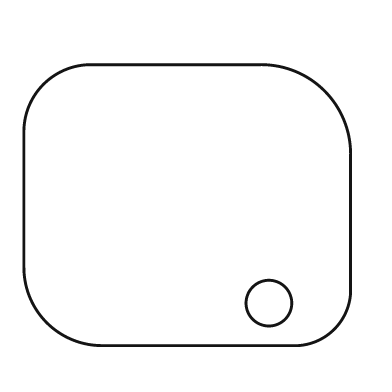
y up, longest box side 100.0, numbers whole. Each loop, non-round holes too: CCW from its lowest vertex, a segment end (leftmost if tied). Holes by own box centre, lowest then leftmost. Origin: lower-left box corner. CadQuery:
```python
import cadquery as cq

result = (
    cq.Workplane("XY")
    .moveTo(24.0, 0.0)
    .lineTo(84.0, 0.0)
    .threePointArc((95.0, 5.0), (100.0, 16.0))
    .lineTo(100.0, 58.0)
    .threePointArc((92.0, 78.0), (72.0, 86.0))
    .lineTo(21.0, 86.0)
    .threePointArc((6.0, 80.0), (0.0, 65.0))
    .lineTo(0.0, 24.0)
    .threePointArc((7.0, 7.0), (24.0, 0.0))
    .close()
    .moveTo(75.0, 13.0)
    .circle(7.0)
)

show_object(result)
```